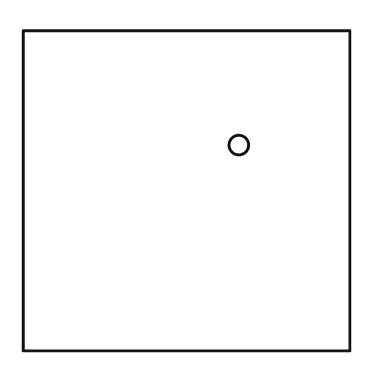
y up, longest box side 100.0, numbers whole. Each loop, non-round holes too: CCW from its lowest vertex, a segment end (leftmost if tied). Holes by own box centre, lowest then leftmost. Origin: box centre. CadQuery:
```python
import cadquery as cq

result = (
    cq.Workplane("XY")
    .moveTo(-50.0, -49.0)
    .lineTo(50.0, -49.0)
    .lineTo(50.0, 49.0)
    .lineTo(-50.0, 49.0)
    .close()
    .moveTo(16.0, 14.0)
    .circle(3.0)
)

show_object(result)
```